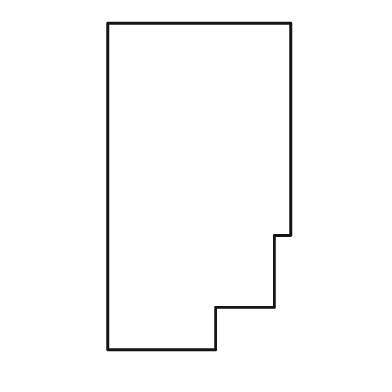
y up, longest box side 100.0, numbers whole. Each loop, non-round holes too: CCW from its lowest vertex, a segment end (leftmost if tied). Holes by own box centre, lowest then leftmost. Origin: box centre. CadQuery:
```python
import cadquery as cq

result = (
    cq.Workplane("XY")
    .moveTo(-28.0, -50.0)
    .lineTo(5.0, -50.0)
    .lineTo(5.0, -37.0)
    .lineTo(23.0, -37.0)
    .lineTo(23.0, -15.0)
    .lineTo(28.0, -15.0)
    .lineTo(28.0, 50.0)
    .lineTo(-28.0, 50.0)
    .close()
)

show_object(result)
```